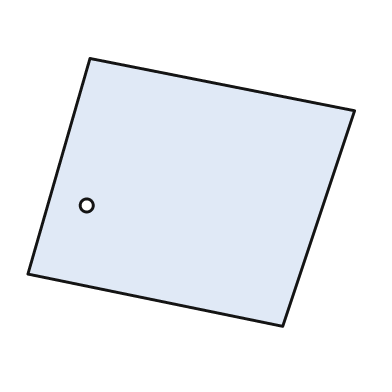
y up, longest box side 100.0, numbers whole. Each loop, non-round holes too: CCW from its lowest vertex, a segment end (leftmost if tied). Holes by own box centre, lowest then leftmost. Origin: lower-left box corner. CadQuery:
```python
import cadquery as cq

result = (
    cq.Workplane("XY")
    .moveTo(78.0, 0.0)
    .lineTo(100.0, 66.0)
    .lineTo(19.0, 82.0)
    .lineTo(0.0, 16.0)
    .close()
    .moveTo(18.0, 37.0)
    .circle(2.0)
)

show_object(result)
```